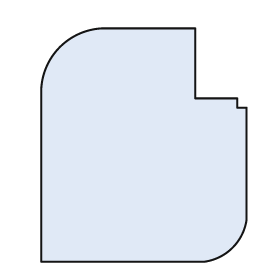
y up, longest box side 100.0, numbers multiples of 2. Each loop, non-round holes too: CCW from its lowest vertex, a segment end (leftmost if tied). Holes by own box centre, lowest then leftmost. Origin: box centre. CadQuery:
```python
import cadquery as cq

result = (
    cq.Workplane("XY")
    .moveTo(-44.0, -50.0)
    .lineTo(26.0, -50.0)
    .threePointArc((38.0, -44.0), (44.0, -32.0))
    .lineTo(44.0, 16.0)
    .lineTo(40.0, 16.0)
    .lineTo(40.0, 20.0)
    .lineTo(22.0, 20.0)
    .lineTo(22.0, 50.0)
    .lineTo(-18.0, 50.0)
    .threePointArc((-36.0, 42.0), (-44.0, 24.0))
    .close()
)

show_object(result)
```